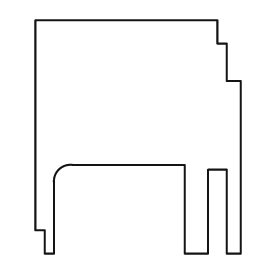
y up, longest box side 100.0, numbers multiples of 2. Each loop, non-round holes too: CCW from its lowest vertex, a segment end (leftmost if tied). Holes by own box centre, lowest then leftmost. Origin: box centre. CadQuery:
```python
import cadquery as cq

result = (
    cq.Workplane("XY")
    .moveTo(-40.0, -50.0)
    .lineTo(-36.0, -50.0)
    .lineTo(-36.0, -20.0)
    .threePointArc((-34.0, -14.0), (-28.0, -12.0))
    .lineTo(20.0, -12.0)
    .lineTo(20.0, -50.0)
    .lineTo(30.0, -50.0)
    .lineTo(30.0, -14.0)
    .lineTo(38.0, -14.0)
    .lineTo(38.0, -50.0)
    .lineTo(44.0, -50.0)
    .lineTo(44.0, 24.0)
    .lineTo(38.0, 24.0)
    .lineTo(38.0, 40.0)
    .lineTo(34.0, 40.0)
    .lineTo(34.0, 50.0)
    .lineTo(-44.0, 50.0)
    .lineTo(-44.0, -40.0)
    .lineTo(-40.0, -40.0)
    .close()
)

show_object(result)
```